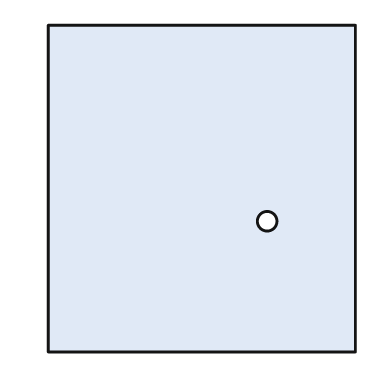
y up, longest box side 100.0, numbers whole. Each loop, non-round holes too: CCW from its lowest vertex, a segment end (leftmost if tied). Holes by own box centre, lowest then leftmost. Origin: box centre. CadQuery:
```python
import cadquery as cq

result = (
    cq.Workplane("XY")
    .moveTo(-47.0, -50.0)
    .lineTo(47.0, -50.0)
    .lineTo(47.0, 50.0)
    .lineTo(-47.0, 50.0)
    .close()
    .moveTo(20.0, -10.0)
    .circle(3.0)
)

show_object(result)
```